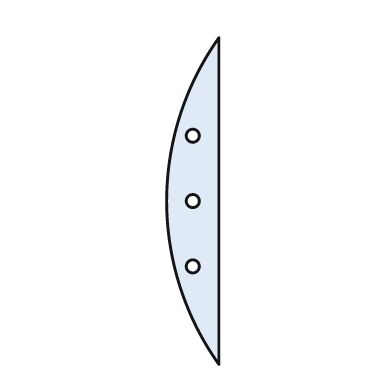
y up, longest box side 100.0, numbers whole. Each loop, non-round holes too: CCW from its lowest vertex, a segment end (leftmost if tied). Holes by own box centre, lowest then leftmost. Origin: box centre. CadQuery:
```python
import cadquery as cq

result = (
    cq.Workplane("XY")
    .moveTo(8.0, -50.0)
    .lineTo(8.0, 50.0)
    .threePointArc((-8.0, 0.0), (8.0, -50.0))
    .close()
    .moveTo(0.0, -20.0)
    .circle(2.0)
    .moveTo(0.0, 0.0)
    .circle(2.0)
    .moveTo(0.0, 20.0)
    .circle(2.0)
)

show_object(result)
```